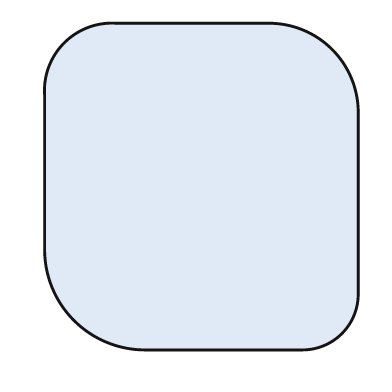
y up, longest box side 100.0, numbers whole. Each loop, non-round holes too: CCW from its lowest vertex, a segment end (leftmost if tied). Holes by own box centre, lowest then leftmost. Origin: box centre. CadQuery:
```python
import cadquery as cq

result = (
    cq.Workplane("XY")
    .moveTo(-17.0, -50.0)
    .lineTo(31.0, -50.0)
    .threePointArc((43.0, -45.0), (48.0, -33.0))
    .lineTo(48.0, 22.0)
    .threePointArc((40.0, 42.0), (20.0, 50.0))
    .lineTo(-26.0, 50.0)
    .threePointArc((-42.0, 44.0), (-48.0, 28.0))
    .lineTo(-48.0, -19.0)
    .threePointArc((-39.0, -41.0), (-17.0, -50.0))
    .close()
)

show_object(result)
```